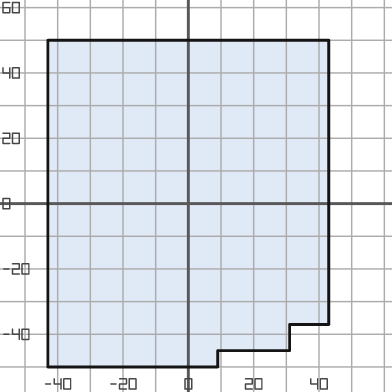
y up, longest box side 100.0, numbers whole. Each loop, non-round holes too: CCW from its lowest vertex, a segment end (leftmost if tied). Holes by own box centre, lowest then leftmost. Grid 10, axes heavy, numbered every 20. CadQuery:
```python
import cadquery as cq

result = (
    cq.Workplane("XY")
    .moveTo(-43.0, -50.0)
    .lineTo(9.0, -50.0)
    .lineTo(9.0, -45.0)
    .lineTo(31.0, -45.0)
    .lineTo(31.0, -37.0)
    .lineTo(43.0, -37.0)
    .lineTo(43.0, 50.0)
    .lineTo(-43.0, 50.0)
    .close()
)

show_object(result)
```